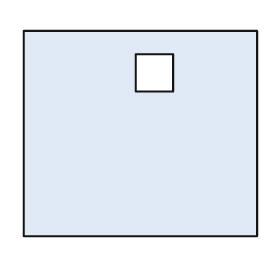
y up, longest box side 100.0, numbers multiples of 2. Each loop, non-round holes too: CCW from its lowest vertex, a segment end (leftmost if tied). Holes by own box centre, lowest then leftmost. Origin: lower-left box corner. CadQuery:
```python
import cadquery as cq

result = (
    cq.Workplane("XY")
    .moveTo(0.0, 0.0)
    .lineTo(100.0, 0.0)
    .lineTo(100.0, 88.0)
    .lineTo(0.0, 88.0)
    .close()
    .moveTo(48.0, 62.0)
    .lineTo(64.0, 62.0)
    .lineTo(64.0, 78.0)
    .lineTo(48.0, 78.0)
    .close()
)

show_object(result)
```